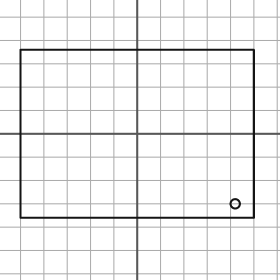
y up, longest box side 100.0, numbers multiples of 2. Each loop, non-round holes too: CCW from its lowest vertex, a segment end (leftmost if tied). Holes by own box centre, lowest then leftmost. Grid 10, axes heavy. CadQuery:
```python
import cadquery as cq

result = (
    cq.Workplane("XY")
    .moveTo(-50.0, -36.0)
    .lineTo(50.0, -36.0)
    .lineTo(50.0, 36.0)
    .lineTo(-50.0, 36.0)
    .close()
    .moveTo(42.0, -30.0)
    .circle(2.0)
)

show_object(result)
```